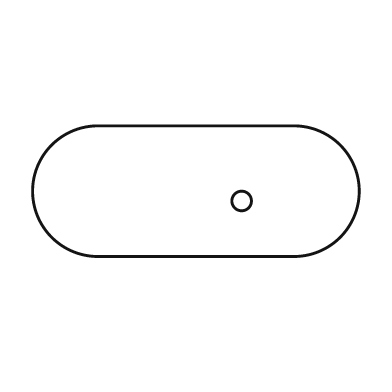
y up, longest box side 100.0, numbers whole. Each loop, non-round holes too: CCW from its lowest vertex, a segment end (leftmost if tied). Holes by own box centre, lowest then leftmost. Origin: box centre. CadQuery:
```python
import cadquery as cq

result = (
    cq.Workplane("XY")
    .moveTo(-30.0, -20.0)
    .lineTo(30.0, -20.0)
    .threePointArc((50.0, 0.0), (30.0, 20.0))
    .lineTo(-30.0, 20.0)
    .threePointArc((-50.0, 0.0), (-30.0, -20.0))
    .close()
    .moveTo(14.0, -3.0)
    .circle(3.0)
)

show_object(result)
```